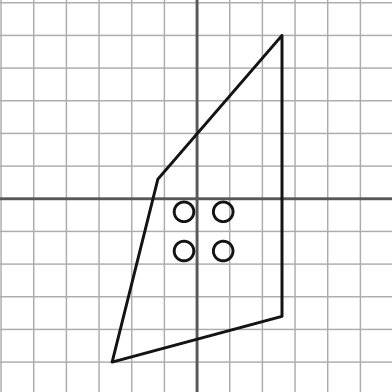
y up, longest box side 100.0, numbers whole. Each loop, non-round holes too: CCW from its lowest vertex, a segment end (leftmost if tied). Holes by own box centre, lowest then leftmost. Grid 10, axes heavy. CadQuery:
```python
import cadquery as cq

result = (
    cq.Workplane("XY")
    .moveTo(-26.0, -50.0)
    .lineTo(26.0, -36.0)
    .lineTo(26.0, 50.0)
    .lineTo(-12.0, 6.0)
    .close()
    .moveTo(-4.0, -16.0)
    .circle(3.0)
    .moveTo(8.0, -16.0)
    .circle(3.0)
    .moveTo(-4.0, -4.0)
    .circle(3.0)
    .moveTo(8.0, -4.0)
    .circle(3.0)
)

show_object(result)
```